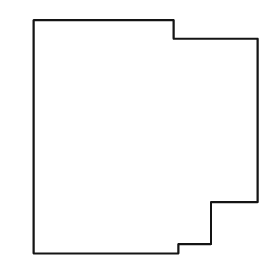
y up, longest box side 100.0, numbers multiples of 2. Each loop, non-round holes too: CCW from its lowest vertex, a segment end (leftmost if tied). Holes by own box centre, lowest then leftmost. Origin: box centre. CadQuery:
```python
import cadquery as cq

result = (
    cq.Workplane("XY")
    .moveTo(-48.0, -50.0)
    .lineTo(14.0, -50.0)
    .lineTo(14.0, -46.0)
    .lineTo(28.0, -46.0)
    .lineTo(28.0, -28.0)
    .lineTo(48.0, -28.0)
    .lineTo(48.0, 42.0)
    .lineTo(12.0, 42.0)
    .lineTo(12.0, 50.0)
    .lineTo(-48.0, 50.0)
    .close()
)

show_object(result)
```